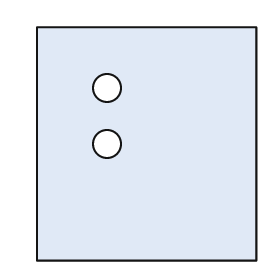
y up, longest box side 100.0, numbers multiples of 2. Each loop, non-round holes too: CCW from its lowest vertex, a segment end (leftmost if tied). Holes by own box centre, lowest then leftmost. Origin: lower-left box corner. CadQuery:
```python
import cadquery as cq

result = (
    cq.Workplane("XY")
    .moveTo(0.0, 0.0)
    .lineTo(94.0, 0.0)
    .lineTo(94.0, 100.0)
    .lineTo(0.0, 100.0)
    .close()
    .moveTo(30.0, 50.0)
    .circle(6.0)
    .moveTo(30.0, 74.0)
    .circle(6.0)
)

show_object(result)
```